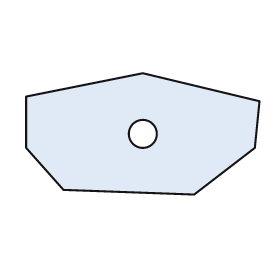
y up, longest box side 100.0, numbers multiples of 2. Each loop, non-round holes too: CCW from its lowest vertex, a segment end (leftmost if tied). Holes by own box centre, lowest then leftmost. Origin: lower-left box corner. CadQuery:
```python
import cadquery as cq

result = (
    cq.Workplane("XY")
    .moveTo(72.0, 0.0)
    .lineTo(98.0, 20.0)
    .lineTo(100.0, 40.0)
    .lineTo(50.0, 52.0)
    .lineTo(0.0, 42.0)
    .lineTo(0.0, 20.0)
    .lineTo(16.0, 2.0)
    .close()
    .moveTo(50.0, 26.0)
    .circle(6.0)
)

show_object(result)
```